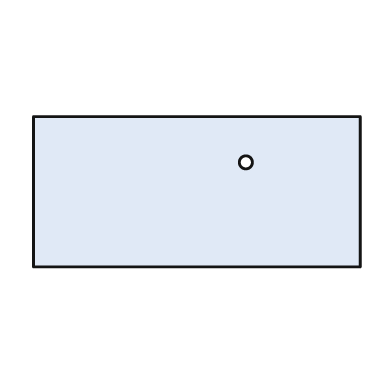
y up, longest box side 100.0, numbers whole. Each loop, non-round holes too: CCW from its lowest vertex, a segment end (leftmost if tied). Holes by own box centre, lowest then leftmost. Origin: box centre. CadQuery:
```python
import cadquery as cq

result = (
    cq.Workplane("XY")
    .moveTo(-50.0, -23.0)
    .lineTo(50.0, -23.0)
    .lineTo(50.0, 23.0)
    .lineTo(-50.0, 23.0)
    .close()
    .moveTo(15.0, 9.0)
    .circle(2.0)
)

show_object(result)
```